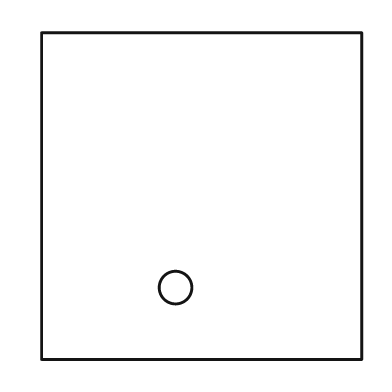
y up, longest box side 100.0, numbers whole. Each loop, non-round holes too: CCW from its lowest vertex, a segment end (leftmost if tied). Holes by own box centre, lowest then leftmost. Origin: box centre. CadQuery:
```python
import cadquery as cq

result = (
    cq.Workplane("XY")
    .moveTo(-49.0, -50.0)
    .lineTo(49.0, -50.0)
    .lineTo(49.0, 50.0)
    .lineTo(-49.0, 50.0)
    .close()
    .moveTo(-8.0, -28.0)
    .circle(5.0)
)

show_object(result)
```